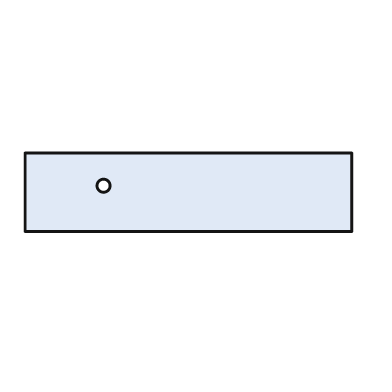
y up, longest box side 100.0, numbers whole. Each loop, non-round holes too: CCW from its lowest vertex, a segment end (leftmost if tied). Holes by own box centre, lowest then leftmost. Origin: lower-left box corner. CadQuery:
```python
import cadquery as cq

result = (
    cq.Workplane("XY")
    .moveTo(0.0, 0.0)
    .lineTo(100.0, 0.0)
    .lineTo(100.0, 24.0)
    .lineTo(0.0, 24.0)
    .close()
    .moveTo(24.0, 14.0)
    .circle(2.0)
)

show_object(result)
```